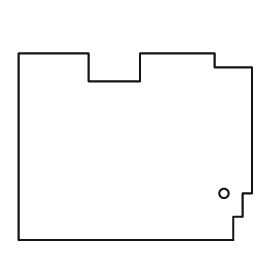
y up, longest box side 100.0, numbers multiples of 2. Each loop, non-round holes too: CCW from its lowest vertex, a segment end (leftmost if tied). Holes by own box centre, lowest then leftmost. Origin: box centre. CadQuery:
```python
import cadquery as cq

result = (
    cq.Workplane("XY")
    .moveTo(-50.0, -40.0)
    .lineTo(42.0, -40.0)
    .lineTo(42.0, -30.0)
    .lineTo(46.0, -30.0)
    .lineTo(46.0, -20.0)
    .lineTo(50.0, -20.0)
    .lineTo(50.0, 34.0)
    .lineTo(34.0, 34.0)
    .lineTo(34.0, 40.0)
    .lineTo(2.0, 40.0)
    .lineTo(2.0, 28.0)
    .lineTo(-20.0, 28.0)
    .lineTo(-20.0, 40.0)
    .lineTo(-50.0, 40.0)
    .close()
    .moveTo(38.0, -20.0)
    .circle(2.0)
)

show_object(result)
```